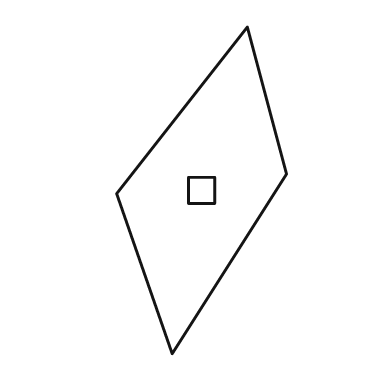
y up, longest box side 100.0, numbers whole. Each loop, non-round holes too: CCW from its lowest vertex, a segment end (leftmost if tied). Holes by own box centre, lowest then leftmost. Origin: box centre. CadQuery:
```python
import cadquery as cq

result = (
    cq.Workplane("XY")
    .moveTo(-9.0, -50.0)
    .lineTo(26.0, 5.0)
    .lineTo(14.0, 50.0)
    .lineTo(-26.0, -1.0)
    .close()
    .moveTo(-4.0, -4.0)
    .lineTo(4.0, -4.0)
    .lineTo(4.0, 4.0)
    .lineTo(-4.0, 4.0)
    .close()
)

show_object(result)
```